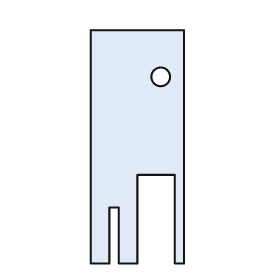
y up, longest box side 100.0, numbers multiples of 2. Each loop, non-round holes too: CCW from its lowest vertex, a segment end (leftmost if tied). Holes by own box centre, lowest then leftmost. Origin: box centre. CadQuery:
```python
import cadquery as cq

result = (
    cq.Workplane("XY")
    .moveTo(-20.0, -50.0)
    .lineTo(-12.0, -50.0)
    .lineTo(-12.0, -26.0)
    .lineTo(-8.0, -26.0)
    .lineTo(-8.0, -50.0)
    .lineTo(0.0, -50.0)
    .lineTo(0.0, -12.0)
    .lineTo(16.0, -12.0)
    .lineTo(16.0, -50.0)
    .lineTo(20.0, -50.0)
    .lineTo(20.0, 50.0)
    .lineTo(-20.0, 50.0)
    .close()
    .moveTo(10.0, 30.0)
    .circle(4.0)
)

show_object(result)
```